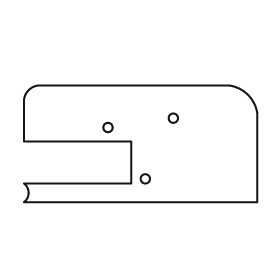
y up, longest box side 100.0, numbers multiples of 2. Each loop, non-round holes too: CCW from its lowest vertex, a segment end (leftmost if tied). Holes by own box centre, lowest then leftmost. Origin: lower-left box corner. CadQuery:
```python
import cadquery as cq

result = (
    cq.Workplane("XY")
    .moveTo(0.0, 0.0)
    .lineTo(100.0, 0.0)
    .lineTo(100.0, 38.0)
    .threePointArc((96.0, 46.0), (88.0, 50.0))
    .lineTo(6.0, 50.0)
    .threePointArc((2.0, 48.0), (0.0, 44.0))
    .lineTo(0.0, 26.0)
    .lineTo(46.0, 26.0)
    .lineTo(46.0, 8.0)
    .lineTo(0.0, 8.0)
    .threePointArc((2.0, 4.0), (0.0, 0.0))
    .close()
    .moveTo(52.0, 10.0)
    .circle(2.0)
    .moveTo(36.0, 32.0)
    .circle(2.0)
    .moveTo(64.0, 36.0)
    .circle(2.0)
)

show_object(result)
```